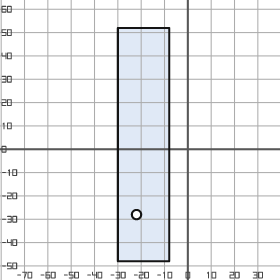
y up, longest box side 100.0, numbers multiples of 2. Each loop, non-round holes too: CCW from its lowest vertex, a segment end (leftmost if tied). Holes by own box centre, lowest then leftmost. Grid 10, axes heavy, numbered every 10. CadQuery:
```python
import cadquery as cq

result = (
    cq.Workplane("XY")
    .moveTo(-30.0, -48.0)
    .lineTo(-8.0, -48.0)
    .lineTo(-8.0, 52.0)
    .lineTo(-30.0, 52.0)
    .close()
    .moveTo(-22.0, -28.0)
    .circle(2.0)
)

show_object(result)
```